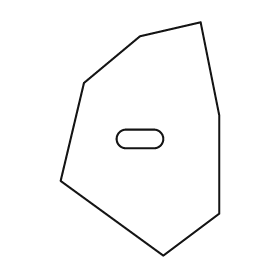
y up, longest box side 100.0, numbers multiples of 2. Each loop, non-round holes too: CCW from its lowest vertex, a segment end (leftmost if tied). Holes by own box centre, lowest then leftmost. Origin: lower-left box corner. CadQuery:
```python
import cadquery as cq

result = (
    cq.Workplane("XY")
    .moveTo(44.0, 0.0)
    .lineTo(68.0, 18.0)
    .lineTo(68.0, 60.0)
    .lineTo(60.0, 100.0)
    .lineTo(34.0, 94.0)
    .lineTo(10.0, 74.0)
    .lineTo(0.0, 32.0)
    .close()
    .moveTo(28.0, 46.0)
    .lineTo(40.0, 46.0)
    .threePointArc((44.0, 50.0), (40.0, 54.0))
    .lineTo(28.0, 54.0)
    .threePointArc((24.0, 50.0), (28.0, 46.0))
    .close()
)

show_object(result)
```